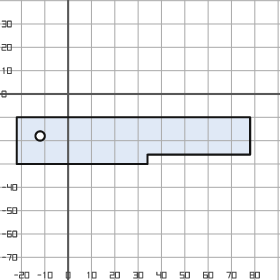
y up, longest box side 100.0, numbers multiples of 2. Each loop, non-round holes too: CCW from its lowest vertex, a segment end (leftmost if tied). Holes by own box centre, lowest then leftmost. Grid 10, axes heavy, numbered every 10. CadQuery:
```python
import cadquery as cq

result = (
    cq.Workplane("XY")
    .moveTo(-22.0, -30.0)
    .lineTo(34.0, -30.0)
    .lineTo(34.0, -26.0)
    .lineTo(78.0, -26.0)
    .lineTo(78.0, -10.0)
    .lineTo(-22.0, -10.0)
    .close()
    .moveTo(-12.0, -18.0)
    .circle(2.0)
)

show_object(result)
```